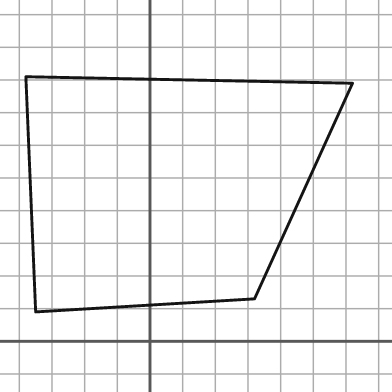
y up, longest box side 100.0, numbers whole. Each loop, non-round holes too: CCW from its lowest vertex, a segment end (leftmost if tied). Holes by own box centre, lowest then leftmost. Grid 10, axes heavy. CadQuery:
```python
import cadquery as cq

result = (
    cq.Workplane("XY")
    .moveTo(-35.0, 9.0)
    .lineTo(32.0, 13.0)
    .lineTo(62.0, 79.0)
    .lineTo(-38.0, 81.0)
    .close()
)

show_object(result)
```